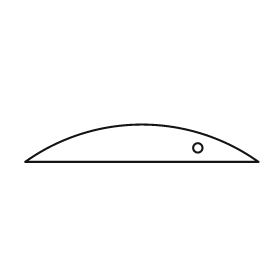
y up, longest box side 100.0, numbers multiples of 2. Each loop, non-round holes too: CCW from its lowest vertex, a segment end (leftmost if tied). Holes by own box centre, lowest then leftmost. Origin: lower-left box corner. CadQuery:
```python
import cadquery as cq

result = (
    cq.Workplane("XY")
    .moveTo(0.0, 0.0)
    .lineTo(100.0, 0.0)
    .threePointArc((50.0, 16.0), (0.0, 0.0))
    .close()
    .moveTo(74.0, 6.0)
    .circle(2.0)
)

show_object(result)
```